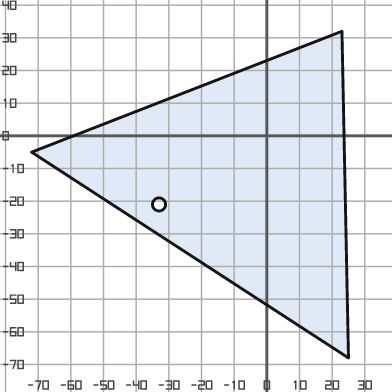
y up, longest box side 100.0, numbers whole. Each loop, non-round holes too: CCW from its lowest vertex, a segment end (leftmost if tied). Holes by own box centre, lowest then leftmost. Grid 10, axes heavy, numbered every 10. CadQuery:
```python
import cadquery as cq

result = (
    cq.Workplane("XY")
    .moveTo(25.0, -68.0)
    .lineTo(23.0, 32.0)
    .lineTo(-72.0, -5.0)
    .close()
    .moveTo(-33.0, -21.0)
    .circle(2.0)
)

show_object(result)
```